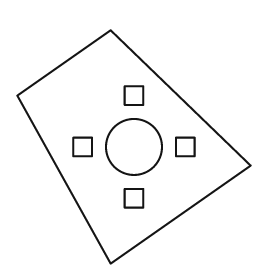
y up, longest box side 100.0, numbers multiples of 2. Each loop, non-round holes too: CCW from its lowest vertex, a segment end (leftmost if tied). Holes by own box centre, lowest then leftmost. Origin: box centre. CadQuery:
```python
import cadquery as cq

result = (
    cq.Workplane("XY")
    .moveTo(-10.0, -50.0)
    .lineTo(50.0, -8.0)
    .lineTo(-10.0, 50.0)
    .lineTo(-50.0, 22.0)
    .close()
    .moveTo(-4.0, -26.0)
    .lineTo(4.0, -26.0)
    .lineTo(4.0, -18.0)
    .lineTo(-4.0, -18.0)
    .close()
    .moveTo(-26.0, -4.0)
    .lineTo(-18.0, -4.0)
    .lineTo(-18.0, 4.0)
    .lineTo(-26.0, 4.0)
    .close()
    .moveTo(0.0, 0.0)
    .circle(12.0)
    .moveTo(18.0, -4.0)
    .lineTo(26.0, -4.0)
    .lineTo(26.0, 4.0)
    .lineTo(18.0, 4.0)
    .close()
    .moveTo(-4.0, 18.0)
    .lineTo(4.0, 18.0)
    .lineTo(4.0, 26.0)
    .lineTo(-4.0, 26.0)
    .close()
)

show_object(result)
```